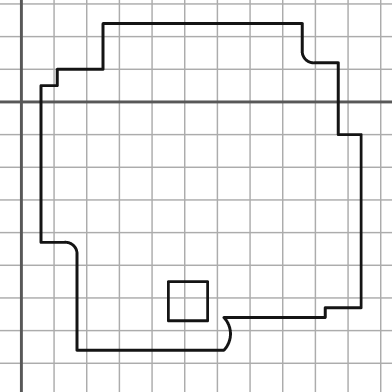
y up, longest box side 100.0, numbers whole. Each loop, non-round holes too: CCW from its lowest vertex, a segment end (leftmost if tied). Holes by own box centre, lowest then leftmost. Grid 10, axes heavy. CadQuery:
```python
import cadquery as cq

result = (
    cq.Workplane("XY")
    .moveTo(17.0, -76.0)
    .lineTo(62.0, -76.0)
    .threePointArc((64.0, -71.0), (62.0, -66.0))
    .lineTo(93.0, -66.0)
    .lineTo(93.0, -63.0)
    .lineTo(104.0, -63.0)
    .lineTo(104.0, -10.0)
    .lineTo(97.0, -10.0)
    .lineTo(97.0, 12.0)
    .lineTo(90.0, 12.0)
    .threePointArc((87.0, 13.0), (86.0, 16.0))
    .lineTo(86.0, 24.0)
    .lineTo(25.0, 24.0)
    .lineTo(25.0, 10.0)
    .lineTo(11.0, 10.0)
    .lineTo(11.0, 5.0)
    .lineTo(6.0, 5.0)
    .lineTo(6.0, -43.0)
    .lineTo(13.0, -43.0)
    .threePointArc((16.0, -44.0), (17.0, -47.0))
    .close()
    .moveTo(45.0, -67.0)
    .lineTo(57.0, -67.0)
    .lineTo(57.0, -55.0)
    .lineTo(45.0, -55.0)
    .close()
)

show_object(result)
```